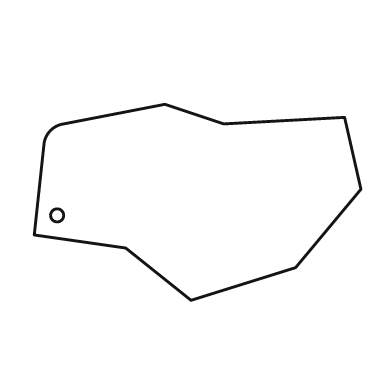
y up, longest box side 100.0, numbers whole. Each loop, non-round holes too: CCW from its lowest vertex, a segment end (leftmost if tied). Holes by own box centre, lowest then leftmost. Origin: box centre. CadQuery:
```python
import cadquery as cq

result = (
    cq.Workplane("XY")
    .moveTo(-2.0, -30.0)
    .lineTo(30.0, -20.0)
    .lineTo(50.0, 4.0)
    .lineTo(45.0, 26.0)
    .lineTo(8.0, 24.0)
    .lineTo(-10.0, 30.0)
    .lineTo(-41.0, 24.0)
    .threePointArc((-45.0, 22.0), (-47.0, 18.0))
    .lineTo(-50.0, -10.0)
    .lineTo(-22.0, -14.0)
    .close()
    .moveTo(-43.0, -4.0)
    .circle(2.0)
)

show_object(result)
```